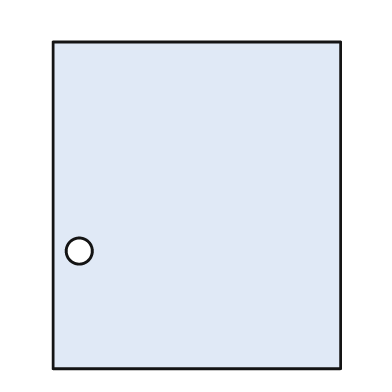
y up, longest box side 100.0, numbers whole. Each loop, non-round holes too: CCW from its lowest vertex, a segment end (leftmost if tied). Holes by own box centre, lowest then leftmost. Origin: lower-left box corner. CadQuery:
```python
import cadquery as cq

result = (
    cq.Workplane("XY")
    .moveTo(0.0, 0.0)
    .lineTo(88.0, 0.0)
    .lineTo(88.0, 100.0)
    .lineTo(0.0, 100.0)
    .close()
    .moveTo(8.0, 36.0)
    .circle(4.0)
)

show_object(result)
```